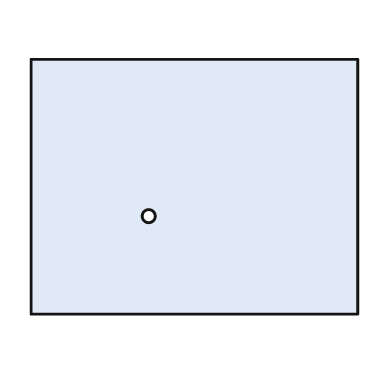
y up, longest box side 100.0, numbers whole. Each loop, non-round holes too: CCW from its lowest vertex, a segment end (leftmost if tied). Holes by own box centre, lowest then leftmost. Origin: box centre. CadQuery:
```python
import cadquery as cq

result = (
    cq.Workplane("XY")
    .moveTo(-50.0, -39.0)
    .lineTo(50.0, -39.0)
    .lineTo(50.0, 39.0)
    .lineTo(-50.0, 39.0)
    .close()
    .moveTo(-14.0, -9.0)
    .circle(2.0)
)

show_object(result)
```